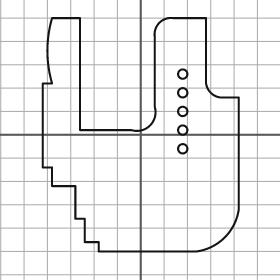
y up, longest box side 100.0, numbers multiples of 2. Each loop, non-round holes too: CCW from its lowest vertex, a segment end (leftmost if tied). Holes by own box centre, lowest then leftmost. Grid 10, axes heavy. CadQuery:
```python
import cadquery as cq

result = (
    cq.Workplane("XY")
    .moveTo(-18.0, -50.0)
    .lineTo(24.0, -50.0)
    .threePointArc((36.0, -44.0), (42.0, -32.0))
    .lineTo(42.0, 16.0)
    .lineTo(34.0, 16.0)
    .threePointArc((30.0, 18.0), (28.0, 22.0))
    .lineTo(28.0, 50.0)
    .lineTo(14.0, 50.0)
    .threePointArc((8.0, 48.0), (6.0, 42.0))
    .lineTo(6.0, 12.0)
    .threePointArc((4.0, 4.0), (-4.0, 2.0))
    .lineTo(-26.0, 2.0)
    .lineTo(-26.0, 50.0)
    .lineTo(-38.0, 50.0)
    .threePointArc((-40.0, 36.0), (-38.0, 22.0))
    .lineTo(-42.0, 22.0)
    .lineTo(-42.0, -14.0)
    .lineTo(-38.0, -14.0)
    .lineTo(-38.0, -22.0)
    .lineTo(-28.0, -22.0)
    .lineTo(-28.0, -36.0)
    .lineTo(-24.0, -36.0)
    .lineTo(-24.0, -46.0)
    .lineTo(-18.0, -46.0)
    .close()
    .moveTo(18.0, -6.0)
    .circle(2.0)
    .moveTo(18.0, 2.0)
    .circle(2.0)
    .moveTo(18.0, 10.0)
    .circle(2.0)
    .moveTo(18.0, 18.0)
    .circle(2.0)
    .moveTo(18.0, 26.0)
    .circle(2.0)
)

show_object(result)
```